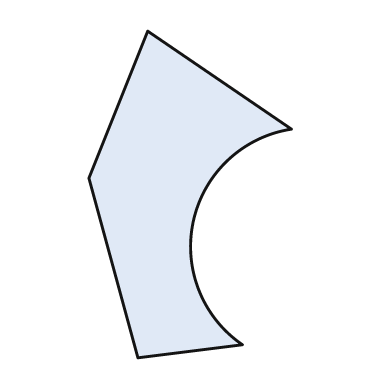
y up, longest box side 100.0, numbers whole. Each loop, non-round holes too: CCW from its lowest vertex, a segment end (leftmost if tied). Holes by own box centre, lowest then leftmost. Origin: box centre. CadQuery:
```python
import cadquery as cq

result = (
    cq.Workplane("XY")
    .moveTo(-16.0, -50.0)
    .lineTo(16.0, -46.0)
    .threePointArc((1.0, -8.0), (31.0, 20.0))
    .lineTo(-13.0, 50.0)
    .lineTo(-31.0, 5.0)
    .close()
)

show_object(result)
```